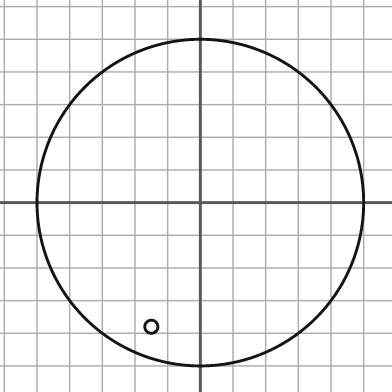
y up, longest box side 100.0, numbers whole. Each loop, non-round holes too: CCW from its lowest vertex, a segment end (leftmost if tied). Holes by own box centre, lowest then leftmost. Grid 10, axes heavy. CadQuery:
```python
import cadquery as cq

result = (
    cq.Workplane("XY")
    .moveTo(0.0, 0.0)
    .circle(50.0)
    .moveTo(-15.0, -38.0)
    .circle(2.0)
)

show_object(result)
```